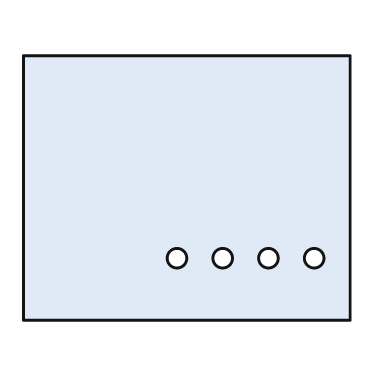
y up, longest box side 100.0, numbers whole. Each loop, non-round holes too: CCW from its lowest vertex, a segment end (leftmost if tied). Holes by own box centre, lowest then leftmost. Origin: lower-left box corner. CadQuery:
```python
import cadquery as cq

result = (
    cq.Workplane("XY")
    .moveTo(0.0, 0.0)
    .lineTo(100.0, 0.0)
    .lineTo(100.0, 81.0)
    .lineTo(0.0, 81.0)
    .close()
    .moveTo(47.0, 19.0)
    .circle(3.0)
    .moveTo(61.0, 19.0)
    .circle(3.0)
    .moveTo(75.0, 19.0)
    .circle(3.0)
    .moveTo(89.0, 19.0)
    .circle(3.0)
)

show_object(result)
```